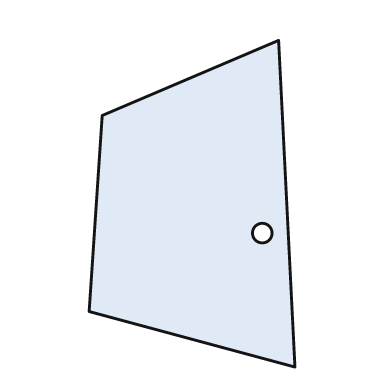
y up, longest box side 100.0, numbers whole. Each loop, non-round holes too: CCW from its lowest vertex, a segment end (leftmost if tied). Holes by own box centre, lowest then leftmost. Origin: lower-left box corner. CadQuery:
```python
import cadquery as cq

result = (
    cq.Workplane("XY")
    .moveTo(63.0, 0.0)
    .lineTo(58.0, 100.0)
    .lineTo(4.0, 77.0)
    .lineTo(0.0, 17.0)
    .close()
    .moveTo(53.0, 41.0)
    .circle(3.0)
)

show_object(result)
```